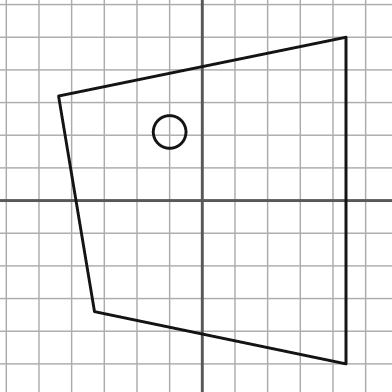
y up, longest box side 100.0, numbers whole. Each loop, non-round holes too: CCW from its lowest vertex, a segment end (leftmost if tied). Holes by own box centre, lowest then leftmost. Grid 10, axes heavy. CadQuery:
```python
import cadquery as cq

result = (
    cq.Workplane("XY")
    .moveTo(44.0, -50.0)
    .lineTo(44.0, 50.0)
    .lineTo(-44.0, 32.0)
    .lineTo(-33.0, -34.0)
    .close()
    .moveTo(-10.0, 21.0)
    .circle(5.0)
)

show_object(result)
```